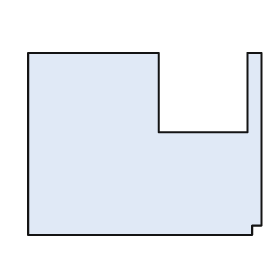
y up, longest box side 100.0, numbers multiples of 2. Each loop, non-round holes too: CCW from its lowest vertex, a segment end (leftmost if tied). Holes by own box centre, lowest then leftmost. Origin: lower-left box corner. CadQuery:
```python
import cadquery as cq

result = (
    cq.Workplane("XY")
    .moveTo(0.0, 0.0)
    .lineTo(96.0, 0.0)
    .lineTo(96.0, 4.0)
    .lineTo(100.0, 4.0)
    .lineTo(100.0, 78.0)
    .lineTo(94.0, 78.0)
    .lineTo(94.0, 44.0)
    .lineTo(56.0, 44.0)
    .lineTo(56.0, 78.0)
    .lineTo(0.0, 78.0)
    .close()
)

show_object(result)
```